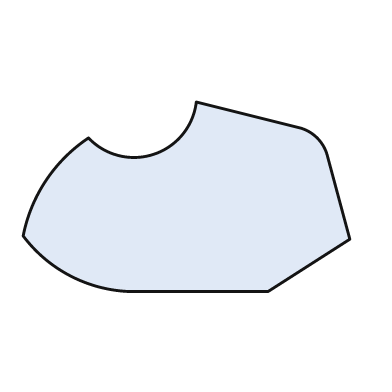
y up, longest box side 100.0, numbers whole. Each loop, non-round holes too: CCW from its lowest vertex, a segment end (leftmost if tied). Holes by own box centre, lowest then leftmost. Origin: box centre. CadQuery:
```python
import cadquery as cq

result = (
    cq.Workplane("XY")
    .moveTo(-18.0, -29.0)
    .lineTo(25.0, -29.0)
    .lineTo(50.0, -13.0)
    .lineTo(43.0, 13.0)
    .threePointArc((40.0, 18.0), (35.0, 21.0))
    .lineTo(3.0, 29.0)
    .threePointArc((-10.0, 13.0), (-30.0, 18.0))
    .threePointArc((-43.0, 5.0), (-50.0, -12.0))
    .threePointArc((-36.0, -24.0), (-18.0, -29.0))
    .close()
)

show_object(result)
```